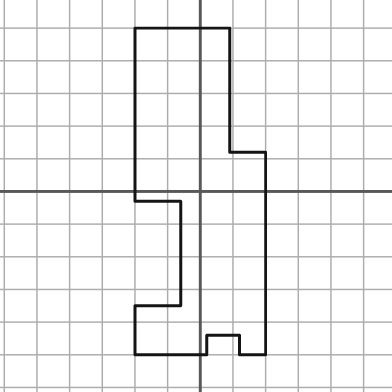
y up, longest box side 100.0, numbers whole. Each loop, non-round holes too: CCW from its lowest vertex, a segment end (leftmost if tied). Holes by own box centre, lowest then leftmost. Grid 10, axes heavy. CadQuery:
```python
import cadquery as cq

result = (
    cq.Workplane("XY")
    .moveTo(-20.0, -50.0)
    .lineTo(2.0, -50.0)
    .lineTo(2.0, -44.0)
    .lineTo(12.0, -44.0)
    .lineTo(12.0, -50.0)
    .lineTo(20.0, -50.0)
    .lineTo(20.0, 12.0)
    .lineTo(9.0, 12.0)
    .lineTo(9.0, 50.0)
    .lineTo(-20.0, 50.0)
    .lineTo(-20.0, -3.0)
    .lineTo(-6.0, -3.0)
    .lineTo(-6.0, -35.0)
    .lineTo(-20.0, -35.0)
    .close()
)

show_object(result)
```